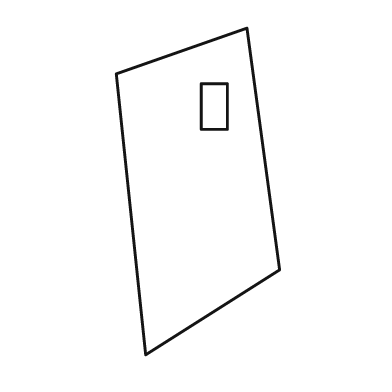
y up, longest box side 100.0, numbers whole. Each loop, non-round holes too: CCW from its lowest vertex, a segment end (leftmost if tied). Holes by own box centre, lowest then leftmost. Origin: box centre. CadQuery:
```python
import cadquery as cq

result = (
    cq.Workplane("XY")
    .moveTo(-16.0, -50.0)
    .lineTo(25.0, -24.0)
    .lineTo(15.0, 50.0)
    .lineTo(-25.0, 36.0)
    .close()
    .moveTo(1.0, 19.0)
    .lineTo(9.0, 19.0)
    .lineTo(9.0, 33.0)
    .lineTo(1.0, 33.0)
    .close()
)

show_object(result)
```